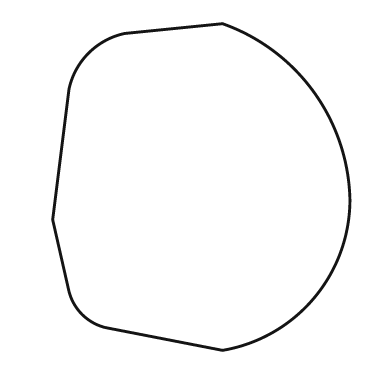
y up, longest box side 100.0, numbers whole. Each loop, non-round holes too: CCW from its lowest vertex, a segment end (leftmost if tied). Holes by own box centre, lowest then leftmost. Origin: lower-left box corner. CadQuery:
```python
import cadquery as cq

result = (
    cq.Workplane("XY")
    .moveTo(52.0, 0.0)
    .threePointArc((80.0, 16.0), (91.0, 46.0))
    .threePointArc((80.0, 79.0), (52.0, 100.0))
    .lineTo(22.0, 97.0)
    .threePointArc((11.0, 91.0), (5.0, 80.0))
    .lineTo(0.0, 40.0)
    .lineTo(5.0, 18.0)
    .threePointArc((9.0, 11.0), (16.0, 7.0))
    .close()
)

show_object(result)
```